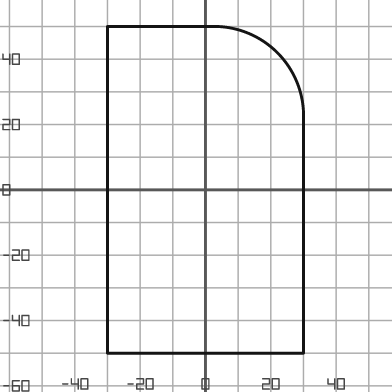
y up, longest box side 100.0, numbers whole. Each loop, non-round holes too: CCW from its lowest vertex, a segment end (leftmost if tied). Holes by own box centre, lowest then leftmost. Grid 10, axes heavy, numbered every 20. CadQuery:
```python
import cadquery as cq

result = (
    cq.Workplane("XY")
    .moveTo(-30.0, -50.0)
    .lineTo(30.0, -50.0)
    .lineTo(30.0, 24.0)
    .threePointArc((22.0, 42.0), (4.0, 50.0))
    .lineTo(-30.0, 50.0)
    .close()
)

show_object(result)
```